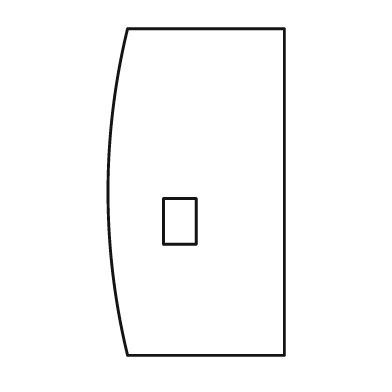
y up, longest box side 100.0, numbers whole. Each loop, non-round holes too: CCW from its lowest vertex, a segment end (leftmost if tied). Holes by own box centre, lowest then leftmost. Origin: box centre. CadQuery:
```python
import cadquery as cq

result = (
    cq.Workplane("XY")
    .moveTo(-21.0, -50.0)
    .lineTo(27.0, -50.0)
    .lineTo(27.0, 50.0)
    .lineTo(-21.0, 50.0)
    .threePointArc((-27.0, 0.0), (-21.0, -50.0))
    .close()
    .moveTo(-10.0, -16.0)
    .lineTo(0.0, -16.0)
    .lineTo(0.0, -2.0)
    .lineTo(-10.0, -2.0)
    .close()
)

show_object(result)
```